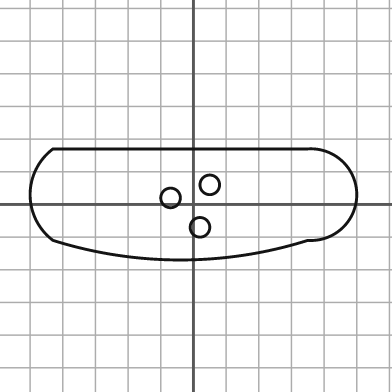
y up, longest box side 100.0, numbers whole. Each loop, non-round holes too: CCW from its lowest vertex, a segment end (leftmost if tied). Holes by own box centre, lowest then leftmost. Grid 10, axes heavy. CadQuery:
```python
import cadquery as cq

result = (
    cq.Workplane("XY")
    .moveTo(-43.0, -11.0)
    .threePointArc((-4.0, -17.0), (35.0, -11.0))
    .threePointArc((50.0, 3.0), (35.0, 17.0))
    .lineTo(-43.0, 17.0)
    .threePointArc((-50.0, 3.0), (-43.0, -11.0))
    .close()
    .moveTo(2.0, -7.0)
    .circle(3.0)
    .moveTo(-7.0, 2.0)
    .circle(3.0)
    .moveTo(5.0, 6.0)
    .circle(3.0)
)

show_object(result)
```